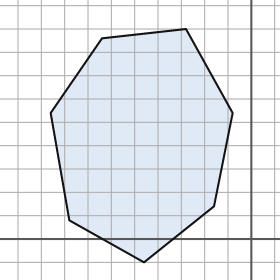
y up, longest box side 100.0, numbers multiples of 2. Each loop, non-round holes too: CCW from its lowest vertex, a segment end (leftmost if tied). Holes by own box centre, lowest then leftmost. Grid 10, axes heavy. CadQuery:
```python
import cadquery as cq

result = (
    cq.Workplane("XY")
    .moveTo(-46.0, -10.0)
    .lineTo(-16.0, 14.0)
    .lineTo(-8.0, 54.0)
    .lineTo(-28.0, 90.0)
    .lineTo(-64.0, 86.0)
    .lineTo(-86.0, 54.0)
    .lineTo(-78.0, 8.0)
    .close()
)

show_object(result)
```